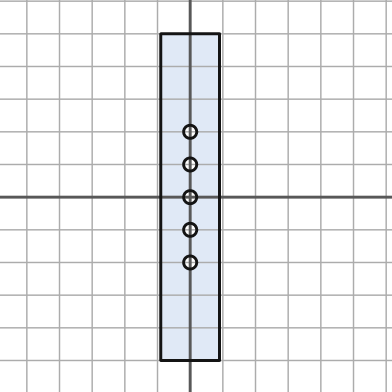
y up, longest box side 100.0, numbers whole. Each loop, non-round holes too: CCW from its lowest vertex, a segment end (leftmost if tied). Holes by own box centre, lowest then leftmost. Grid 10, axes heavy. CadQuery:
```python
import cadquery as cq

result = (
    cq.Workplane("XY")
    .moveTo(-9.0, -50.0)
    .lineTo(9.0, -50.0)
    .lineTo(9.0, 50.0)
    .lineTo(-9.0, 50.0)
    .close()
    .moveTo(0.0, -20.0)
    .circle(2.0)
    .moveTo(0.0, -10.0)
    .circle(2.0)
    .moveTo(0.0, 0.0)
    .circle(2.0)
    .moveTo(0.0, 10.0)
    .circle(2.0)
    .moveTo(0.0, 20.0)
    .circle(2.0)
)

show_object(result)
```